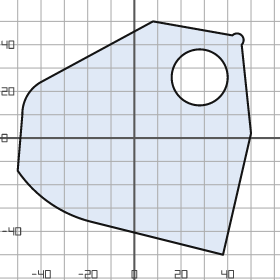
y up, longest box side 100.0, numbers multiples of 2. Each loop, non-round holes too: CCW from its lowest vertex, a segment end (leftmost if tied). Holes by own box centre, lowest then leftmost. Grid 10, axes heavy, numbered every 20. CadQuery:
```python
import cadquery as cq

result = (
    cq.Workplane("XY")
    .moveTo(38.0, -50.0)
    .lineTo(50.0, 2.0)
    .lineTo(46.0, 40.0)
    .threePointArc((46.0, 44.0), (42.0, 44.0))
    .lineTo(8.0, 50.0)
    .lineTo(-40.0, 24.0)
    .threePointArc((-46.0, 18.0), (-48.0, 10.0))
    .lineTo(-50.0, -14.0)
    .threePointArc((-36.0, -28.0), (-18.0, -36.0))
    .close()
    .moveTo(28.0, 26.0)
    .circle(12.0)
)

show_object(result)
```